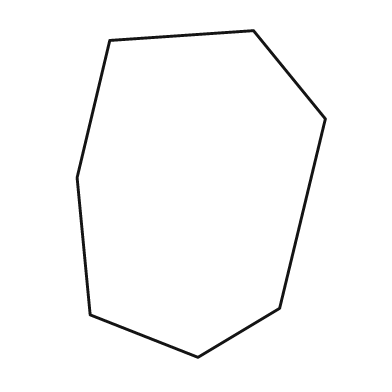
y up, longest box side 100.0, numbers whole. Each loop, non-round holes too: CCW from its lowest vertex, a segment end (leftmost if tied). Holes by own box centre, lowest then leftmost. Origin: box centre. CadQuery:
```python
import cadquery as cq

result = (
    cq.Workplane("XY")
    .moveTo(-1.0, -50.0)
    .lineTo(24.0, -35.0)
    .lineTo(38.0, 23.0)
    .lineTo(16.0, 50.0)
    .lineTo(-28.0, 47.0)
    .lineTo(-38.0, 5.0)
    .lineTo(-34.0, -37.0)
    .close()
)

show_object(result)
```